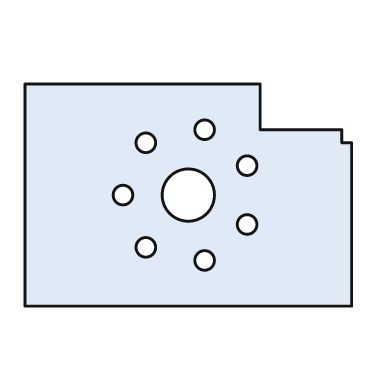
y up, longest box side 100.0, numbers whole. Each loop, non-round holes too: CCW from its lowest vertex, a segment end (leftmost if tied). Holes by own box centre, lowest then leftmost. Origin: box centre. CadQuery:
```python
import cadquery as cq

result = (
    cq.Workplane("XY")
    .moveTo(-50.0, -34.0)
    .lineTo(50.0, -34.0)
    .lineTo(50.0, 16.0)
    .lineTo(47.0, 16.0)
    .lineTo(47.0, 20.0)
    .lineTo(22.0, 20.0)
    .lineTo(22.0, 34.0)
    .lineTo(-50.0, 34.0)
    .close()
    .moveTo(5.0, -20.0)
    .circle(3.0)
    .moveTo(-13.0, -16.0)
    .circle(3.0)
    .moveTo(18.0, -9.0)
    .circle(3.0)
    .moveTo(-20.0, 0.0)
    .circle(3.0)
    .moveTo(0.0, 0.0)
    .circle(8.0)
    .moveTo(18.0, 9.0)
    .circle(3.0)
    .moveTo(-13.0, 16.0)
    .circle(3.0)
    .moveTo(5.0, 20.0)
    .circle(3.0)
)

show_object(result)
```